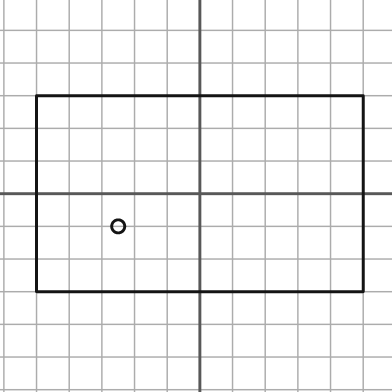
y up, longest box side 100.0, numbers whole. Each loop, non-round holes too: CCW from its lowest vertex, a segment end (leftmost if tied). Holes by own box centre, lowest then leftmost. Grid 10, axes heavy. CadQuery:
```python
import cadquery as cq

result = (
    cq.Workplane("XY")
    .moveTo(-50.0, -30.0)
    .lineTo(50.0, -30.0)
    .lineTo(50.0, 30.0)
    .lineTo(-50.0, 30.0)
    .close()
    .moveTo(-25.0, -10.0)
    .circle(2.0)
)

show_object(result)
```